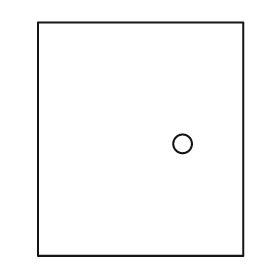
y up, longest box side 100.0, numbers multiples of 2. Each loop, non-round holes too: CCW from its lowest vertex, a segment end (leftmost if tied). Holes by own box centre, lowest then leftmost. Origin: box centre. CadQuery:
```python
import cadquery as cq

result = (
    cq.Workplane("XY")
    .moveTo(-44.0, -50.0)
    .lineTo(44.0, -50.0)
    .lineTo(44.0, 50.0)
    .lineTo(-44.0, 50.0)
    .close()
    .moveTo(18.0, -2.0)
    .circle(4.0)
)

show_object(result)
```